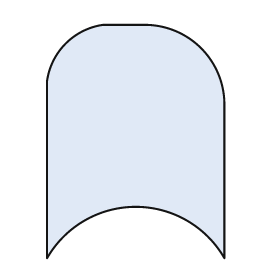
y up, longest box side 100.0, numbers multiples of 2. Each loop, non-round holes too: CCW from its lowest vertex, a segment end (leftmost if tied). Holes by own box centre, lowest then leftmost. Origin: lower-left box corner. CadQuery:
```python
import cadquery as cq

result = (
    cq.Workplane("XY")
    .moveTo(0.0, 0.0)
    .threePointArc((38.0, 22.0), (76.0, 0.0))
    .lineTo(76.0, 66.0)
    .threePointArc((66.0, 90.0), (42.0, 100.0))
    .lineTo(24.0, 100.0)
    .threePointArc((8.0, 92.0), (0.0, 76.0))
    .close()
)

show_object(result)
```